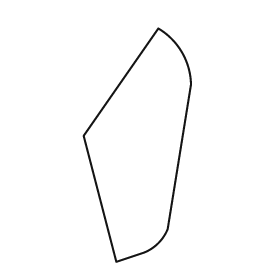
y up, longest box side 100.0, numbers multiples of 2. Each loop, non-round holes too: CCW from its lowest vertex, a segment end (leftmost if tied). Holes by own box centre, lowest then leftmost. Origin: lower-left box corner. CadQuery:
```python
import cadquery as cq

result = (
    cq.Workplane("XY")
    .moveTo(14.0, 0.0)
    .lineTo(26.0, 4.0)
    .threePointArc((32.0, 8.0), (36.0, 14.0))
    .lineTo(46.0, 76.0)
    .threePointArc((42.0, 90.0), (32.0, 100.0))
    .lineTo(0.0, 54.0)
    .close()
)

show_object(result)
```